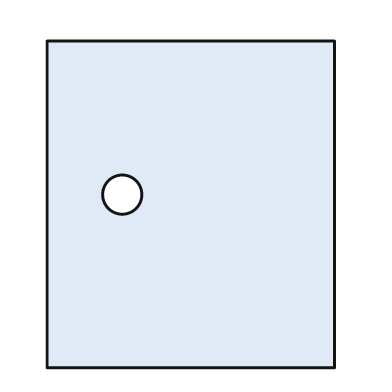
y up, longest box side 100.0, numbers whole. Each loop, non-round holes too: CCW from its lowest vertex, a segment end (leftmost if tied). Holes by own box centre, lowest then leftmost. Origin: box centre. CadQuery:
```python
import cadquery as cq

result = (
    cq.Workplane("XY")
    .moveTo(-44.0, -50.0)
    .lineTo(44.0, -50.0)
    .lineTo(44.0, 50.0)
    .lineTo(-44.0, 50.0)
    .close()
    .moveTo(-21.0, 3.0)
    .circle(6.0)
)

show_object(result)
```